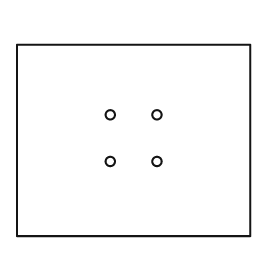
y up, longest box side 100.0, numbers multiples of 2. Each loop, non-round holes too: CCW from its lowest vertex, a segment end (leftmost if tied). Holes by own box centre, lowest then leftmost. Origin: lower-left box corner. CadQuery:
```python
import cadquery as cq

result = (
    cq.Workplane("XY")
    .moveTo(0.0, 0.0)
    .lineTo(100.0, 0.0)
    .lineTo(100.0, 82.0)
    .lineTo(0.0, 82.0)
    .close()
    .moveTo(40.0, 32.0)
    .circle(2.0)
    .moveTo(60.0, 32.0)
    .circle(2.0)
    .moveTo(40.0, 52.0)
    .circle(2.0)
    .moveTo(60.0, 52.0)
    .circle(2.0)
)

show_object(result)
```